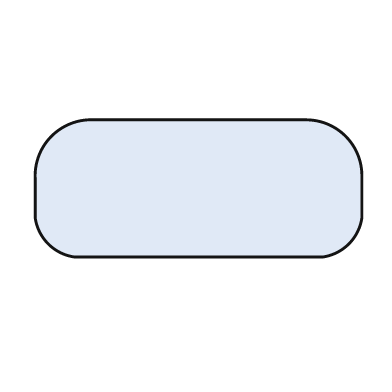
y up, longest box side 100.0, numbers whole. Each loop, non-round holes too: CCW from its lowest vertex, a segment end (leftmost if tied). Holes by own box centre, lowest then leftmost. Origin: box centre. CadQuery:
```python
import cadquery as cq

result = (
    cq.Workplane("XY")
    .moveTo(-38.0, -21.0)
    .lineTo(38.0, -21.0)
    .threePointArc((46.0, -17.0), (50.0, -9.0))
    .lineTo(50.0, 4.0)
    .threePointArc((45.0, 16.0), (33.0, 21.0))
    .lineTo(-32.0, 21.0)
    .threePointArc((-45.0, 16.0), (-50.0, 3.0))
    .lineTo(-50.0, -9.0)
    .threePointArc((-46.0, -17.0), (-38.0, -21.0))
    .close()
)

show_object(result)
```